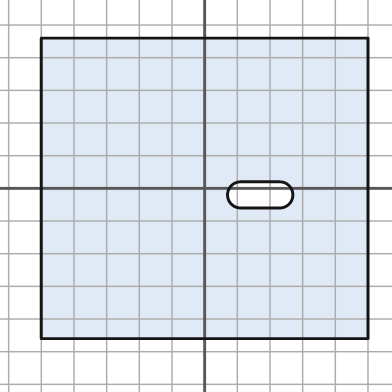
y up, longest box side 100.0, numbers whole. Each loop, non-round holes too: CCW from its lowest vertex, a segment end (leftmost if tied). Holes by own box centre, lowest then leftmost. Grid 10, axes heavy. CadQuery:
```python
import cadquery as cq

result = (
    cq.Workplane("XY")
    .moveTo(-50.0, -46.0)
    .lineTo(50.0, -46.0)
    .lineTo(50.0, 46.0)
    .lineTo(-50.0, 46.0)
    .close()
    .moveTo(11.0, -6.0)
    .lineTo(23.0, -6.0)
    .threePointArc((27.0, -2.0), (23.0, 2.0))
    .lineTo(11.0, 2.0)
    .threePointArc((7.0, -2.0), (11.0, -6.0))
    .close()
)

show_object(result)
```